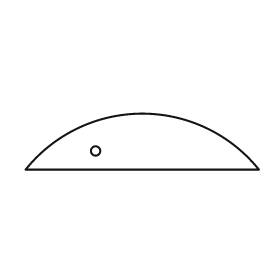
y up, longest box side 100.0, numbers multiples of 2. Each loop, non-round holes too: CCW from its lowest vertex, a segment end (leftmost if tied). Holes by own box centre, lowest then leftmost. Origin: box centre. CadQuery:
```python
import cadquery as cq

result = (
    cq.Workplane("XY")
    .moveTo(-50.0, -12.0)
    .lineTo(50.0, -12.0)
    .threePointArc((0.0, 12.0), (-50.0, -12.0))
    .close()
    .moveTo(-20.0, -4.0)
    .circle(2.0)
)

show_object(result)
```